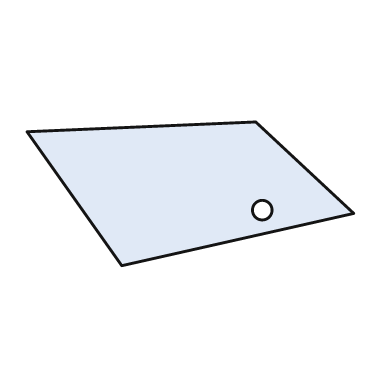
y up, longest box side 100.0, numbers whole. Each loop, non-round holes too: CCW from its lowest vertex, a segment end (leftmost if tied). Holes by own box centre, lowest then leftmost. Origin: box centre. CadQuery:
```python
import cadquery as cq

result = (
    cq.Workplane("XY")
    .moveTo(-21.0, -22.0)
    .lineTo(50.0, -6.0)
    .lineTo(20.0, 22.0)
    .lineTo(-50.0, 19.0)
    .close()
    .moveTo(22.0, -5.0)
    .circle(3.0)
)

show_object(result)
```